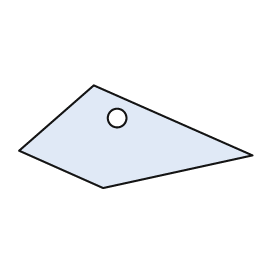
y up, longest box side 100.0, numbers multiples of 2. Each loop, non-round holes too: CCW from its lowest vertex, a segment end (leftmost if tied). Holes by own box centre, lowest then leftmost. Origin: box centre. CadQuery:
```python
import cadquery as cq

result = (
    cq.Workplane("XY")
    .moveTo(-14.0, -22.0)
    .lineTo(50.0, -8.0)
    .lineTo(-18.0, 22.0)
    .lineTo(-50.0, -6.0)
    .close()
    .moveTo(-8.0, 8.0)
    .circle(4.0)
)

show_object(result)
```